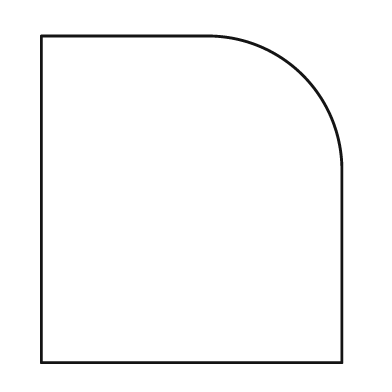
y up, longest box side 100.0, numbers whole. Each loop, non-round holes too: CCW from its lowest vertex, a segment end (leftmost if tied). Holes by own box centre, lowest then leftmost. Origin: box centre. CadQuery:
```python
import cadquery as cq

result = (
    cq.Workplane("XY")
    .moveTo(-46.0, -50.0)
    .lineTo(46.0, -50.0)
    .lineTo(46.0, 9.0)
    .threePointArc((34.0, 38.0), (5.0, 50.0))
    .lineTo(-46.0, 50.0)
    .close()
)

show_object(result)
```